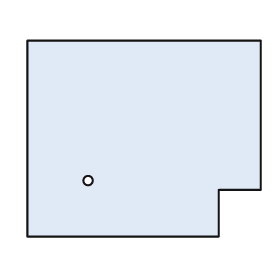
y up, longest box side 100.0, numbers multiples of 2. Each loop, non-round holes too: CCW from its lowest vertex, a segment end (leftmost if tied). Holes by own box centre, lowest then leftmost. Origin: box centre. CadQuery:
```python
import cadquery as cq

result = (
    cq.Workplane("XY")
    .moveTo(-50.0, -42.0)
    .lineTo(32.0, -42.0)
    .lineTo(32.0, -22.0)
    .lineTo(50.0, -22.0)
    .lineTo(50.0, 42.0)
    .lineTo(-50.0, 42.0)
    .close()
    .moveTo(-24.0, -18.0)
    .circle(2.0)
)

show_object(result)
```